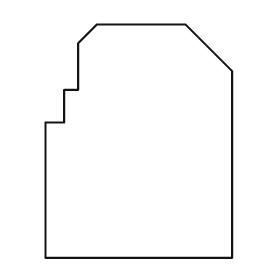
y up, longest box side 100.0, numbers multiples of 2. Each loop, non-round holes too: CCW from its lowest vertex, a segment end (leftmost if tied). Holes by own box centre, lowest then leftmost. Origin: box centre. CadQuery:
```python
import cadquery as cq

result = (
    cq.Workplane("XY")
    .moveTo(-40.0, -50.0)
    .lineTo(40.0, -50.0)
    .lineTo(40.0, 30.0)
    .lineTo(20.0, 50.0)
    .lineTo(-18.0, 50.0)
    .lineTo(-26.0, 42.0)
    .lineTo(-26.0, 22.0)
    .lineTo(-32.0, 22.0)
    .lineTo(-32.0, 8.0)
    .lineTo(-40.0, 8.0)
    .close()
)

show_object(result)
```